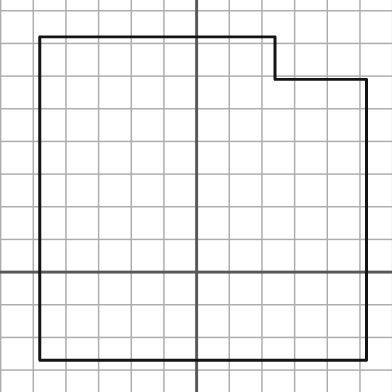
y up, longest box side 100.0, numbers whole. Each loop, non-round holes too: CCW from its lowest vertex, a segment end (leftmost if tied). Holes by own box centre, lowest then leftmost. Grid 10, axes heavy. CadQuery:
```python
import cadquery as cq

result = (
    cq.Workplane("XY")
    .moveTo(-48.0, -27.0)
    .lineTo(52.0, -27.0)
    .lineTo(52.0, 59.0)
    .lineTo(24.0, 59.0)
    .lineTo(24.0, 72.0)
    .lineTo(-48.0, 72.0)
    .close()
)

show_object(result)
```